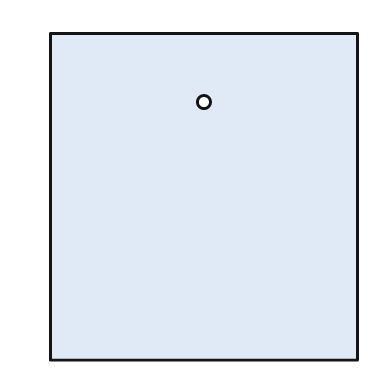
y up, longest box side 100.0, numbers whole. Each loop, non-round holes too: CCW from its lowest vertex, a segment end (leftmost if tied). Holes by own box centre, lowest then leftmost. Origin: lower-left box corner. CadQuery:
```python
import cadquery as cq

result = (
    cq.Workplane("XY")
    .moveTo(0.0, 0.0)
    .lineTo(94.0, 0.0)
    .lineTo(94.0, 100.0)
    .lineTo(0.0, 100.0)
    .close()
    .moveTo(47.0, 79.0)
    .circle(2.0)
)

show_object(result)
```